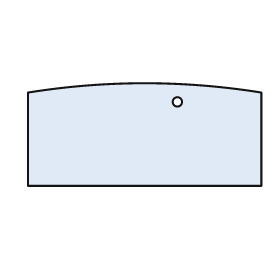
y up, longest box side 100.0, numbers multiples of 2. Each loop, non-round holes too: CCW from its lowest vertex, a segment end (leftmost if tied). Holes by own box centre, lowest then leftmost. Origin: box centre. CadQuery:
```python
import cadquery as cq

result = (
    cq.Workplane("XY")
    .moveTo(-50.0, -22.0)
    .lineTo(50.0, -22.0)
    .lineTo(50.0, 18.0)
    .threePointArc((0.0, 22.0), (-50.0, 18.0))
    .close()
    .moveTo(14.0, 14.0)
    .circle(2.0)
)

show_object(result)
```